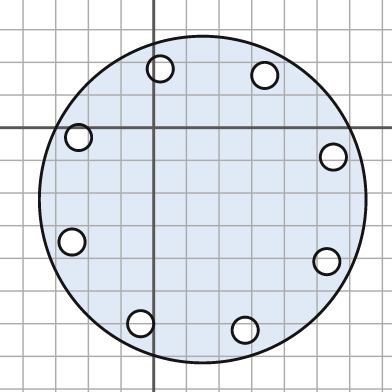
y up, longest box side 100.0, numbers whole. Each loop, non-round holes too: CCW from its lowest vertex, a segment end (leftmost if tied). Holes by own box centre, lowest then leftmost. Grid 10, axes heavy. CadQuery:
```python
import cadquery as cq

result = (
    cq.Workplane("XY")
    .moveTo(15.0, -22.0)
    .circle(50.0)
    .moveTo(28.0, -62.0)
    .circle(4.0)
    .moveTo(-4.0, -60.0)
    .circle(4.0)
    .moveTo(53.0, -41.0)
    .circle(4.0)
    .moveTo(-25.0, -35.0)
    .circle(4.0)
    .moveTo(55.0, -9.0)
    .circle(4.0)
    .moveTo(-23.0, -3.0)
    .circle(4.0)
    .moveTo(34.0, 16.0)
    .circle(4.0)
    .moveTo(2.0, 18.0)
    .circle(4.0)
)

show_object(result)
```